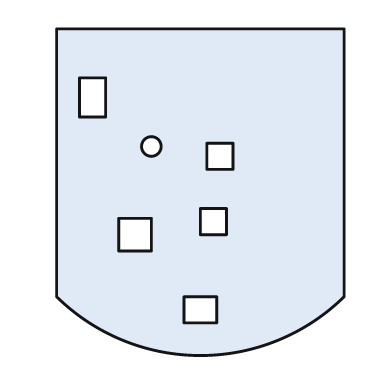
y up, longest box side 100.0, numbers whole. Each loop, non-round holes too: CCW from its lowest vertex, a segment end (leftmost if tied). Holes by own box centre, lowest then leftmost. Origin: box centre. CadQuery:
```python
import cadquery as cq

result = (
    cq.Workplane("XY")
    .moveTo(-44.0, -32.0)
    .threePointArc((0.0, -50.0), (44.0, -32.0))
    .lineTo(44.0, 50.0)
    .lineTo(-44.0, 50.0)
    .close()
    .moveTo(-5.0, -40.0)
    .lineTo(5.0, -40.0)
    .lineTo(5.0, -32.0)
    .lineTo(-5.0, -32.0)
    .close()
    .moveTo(-25.0, -18.0)
    .lineTo(-15.0, -18.0)
    .lineTo(-15.0, -8.0)
    .lineTo(-25.0, -8.0)
    .close()
    .moveTo(0.0, -13.0)
    .lineTo(8.0, -13.0)
    .lineTo(8.0, -5.0)
    .lineTo(0.0, -5.0)
    .close()
    .moveTo(2.0, 7.0)
    .lineTo(10.0, 7.0)
    .lineTo(10.0, 15.0)
    .lineTo(2.0, 15.0)
    .close()
    .moveTo(-15.0, 14.0)
    .circle(3.0)
    .moveTo(-37.0, 23.0)
    .lineTo(-29.0, 23.0)
    .lineTo(-29.0, 35.0)
    .lineTo(-37.0, 35.0)
    .close()
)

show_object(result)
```